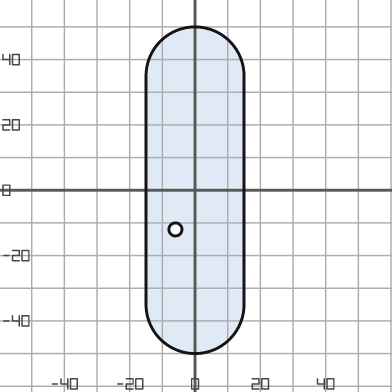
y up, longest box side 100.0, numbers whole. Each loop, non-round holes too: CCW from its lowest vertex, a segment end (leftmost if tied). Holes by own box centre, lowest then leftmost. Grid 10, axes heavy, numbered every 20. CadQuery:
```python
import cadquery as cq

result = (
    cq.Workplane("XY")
    .moveTo(-15.0, -35.0)
    .threePointArc((0.0, -50.0), (15.0, -35.0))
    .lineTo(15.0, 35.0)
    .threePointArc((0.0, 50.0), (-15.0, 35.0))
    .close()
    .moveTo(-6.0, -12.0)
    .circle(2.0)
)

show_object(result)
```